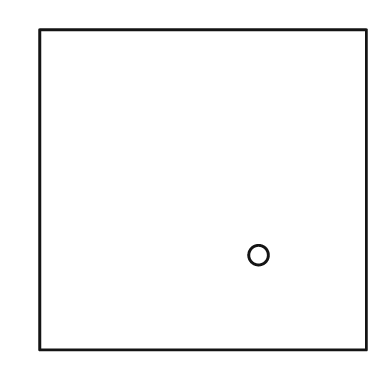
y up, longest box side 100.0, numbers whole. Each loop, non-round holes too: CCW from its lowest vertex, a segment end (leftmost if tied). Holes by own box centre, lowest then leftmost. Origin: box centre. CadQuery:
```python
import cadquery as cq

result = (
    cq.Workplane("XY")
    .moveTo(-50.0, -49.0)
    .lineTo(50.0, -49.0)
    .lineTo(50.0, 49.0)
    .lineTo(-50.0, 49.0)
    .close()
    .moveTo(17.0, -20.0)
    .circle(3.0)
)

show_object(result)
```